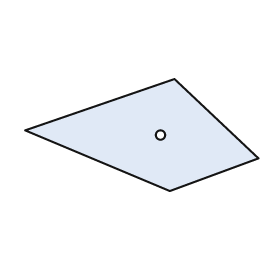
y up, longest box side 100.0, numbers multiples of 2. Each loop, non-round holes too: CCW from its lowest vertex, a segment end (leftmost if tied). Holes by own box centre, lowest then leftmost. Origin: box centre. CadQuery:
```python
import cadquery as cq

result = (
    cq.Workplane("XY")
    .moveTo(12.0, -24.0)
    .lineTo(50.0, -10.0)
    .lineTo(14.0, 24.0)
    .lineTo(-50.0, 2.0)
    .close()
    .moveTo(8.0, 0.0)
    .circle(2.0)
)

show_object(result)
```